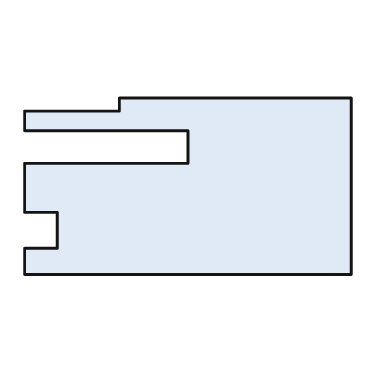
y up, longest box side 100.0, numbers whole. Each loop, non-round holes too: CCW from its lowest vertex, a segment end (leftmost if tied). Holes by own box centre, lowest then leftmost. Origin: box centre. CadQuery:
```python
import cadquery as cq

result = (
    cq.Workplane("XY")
    .moveTo(-50.0, -27.0)
    .lineTo(50.0, -27.0)
    .lineTo(50.0, 27.0)
    .lineTo(-21.0, 27.0)
    .lineTo(-21.0, 23.0)
    .lineTo(-50.0, 23.0)
    .lineTo(-50.0, 17.0)
    .lineTo(0.0, 17.0)
    .lineTo(0.0, 7.0)
    .lineTo(-50.0, 7.0)
    .lineTo(-50.0, -8.0)
    .lineTo(-40.0, -8.0)
    .lineTo(-40.0, -19.0)
    .lineTo(-50.0, -19.0)
    .close()
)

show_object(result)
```